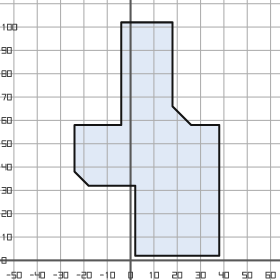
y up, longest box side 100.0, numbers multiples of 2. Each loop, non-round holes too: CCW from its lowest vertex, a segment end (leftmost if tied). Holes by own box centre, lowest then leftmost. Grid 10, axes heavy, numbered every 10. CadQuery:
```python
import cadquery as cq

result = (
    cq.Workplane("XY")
    .moveTo(2.0, 2.0)
    .lineTo(38.0, 2.0)
    .lineTo(38.0, 58.0)
    .lineTo(26.0, 58.0)
    .lineTo(18.0, 66.0)
    .lineTo(18.0, 102.0)
    .lineTo(-4.0, 102.0)
    .lineTo(-4.0, 58.0)
    .lineTo(-24.0, 58.0)
    .lineTo(-24.0, 38.0)
    .lineTo(-18.0, 32.0)
    .lineTo(2.0, 32.0)
    .close()
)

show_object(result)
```